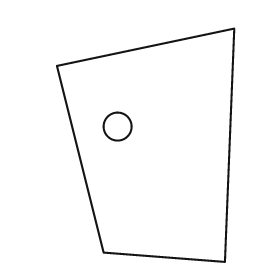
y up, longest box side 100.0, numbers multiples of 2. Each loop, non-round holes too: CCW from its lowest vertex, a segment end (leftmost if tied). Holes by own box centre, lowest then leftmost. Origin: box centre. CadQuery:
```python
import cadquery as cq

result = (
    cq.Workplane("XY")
    .moveTo(34.0, -50.0)
    .lineTo(38.0, 50.0)
    .lineTo(-38.0, 34.0)
    .lineTo(-18.0, -46.0)
    .close()
    .moveTo(-12.0, 8.0)
    .circle(6.0)
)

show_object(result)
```